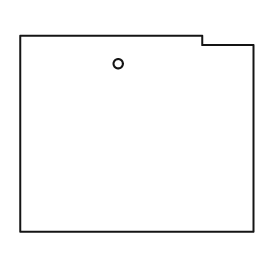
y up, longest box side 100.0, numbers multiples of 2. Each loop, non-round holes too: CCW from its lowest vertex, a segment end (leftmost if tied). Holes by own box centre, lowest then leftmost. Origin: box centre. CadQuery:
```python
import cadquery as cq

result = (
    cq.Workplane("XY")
    .moveTo(-50.0, -42.0)
    .lineTo(50.0, -42.0)
    .lineTo(50.0, 38.0)
    .lineTo(28.0, 38.0)
    .lineTo(28.0, 42.0)
    .lineTo(-50.0, 42.0)
    .close()
    .moveTo(-8.0, 30.0)
    .circle(2.0)
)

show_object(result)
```